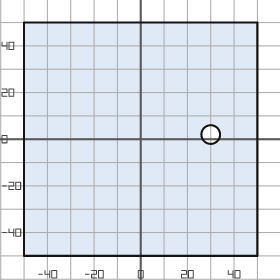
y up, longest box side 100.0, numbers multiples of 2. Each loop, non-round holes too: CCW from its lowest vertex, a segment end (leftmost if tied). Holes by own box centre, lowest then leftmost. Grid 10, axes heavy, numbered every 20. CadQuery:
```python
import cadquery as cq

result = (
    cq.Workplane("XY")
    .moveTo(-50.0, -50.0)
    .lineTo(50.0, -50.0)
    .lineTo(50.0, 50.0)
    .lineTo(-50.0, 50.0)
    .close()
    .moveTo(30.0, 2.0)
    .circle(4.0)
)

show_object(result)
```